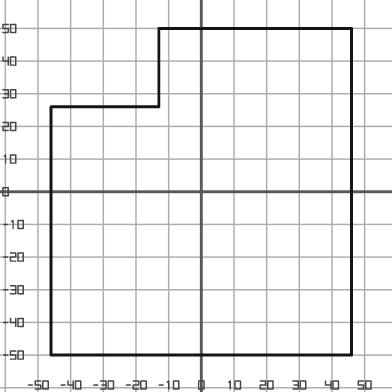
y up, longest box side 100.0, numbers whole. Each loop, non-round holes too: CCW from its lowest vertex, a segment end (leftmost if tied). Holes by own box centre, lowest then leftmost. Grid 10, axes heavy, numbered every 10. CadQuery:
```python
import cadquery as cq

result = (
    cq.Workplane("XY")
    .moveTo(-46.0, -50.0)
    .lineTo(46.0, -50.0)
    .lineTo(46.0, 50.0)
    .lineTo(-13.0, 50.0)
    .lineTo(-13.0, 26.0)
    .lineTo(-46.0, 26.0)
    .close()
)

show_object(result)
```